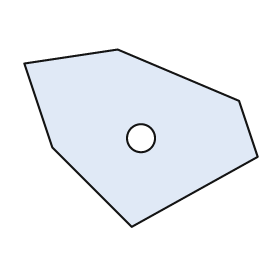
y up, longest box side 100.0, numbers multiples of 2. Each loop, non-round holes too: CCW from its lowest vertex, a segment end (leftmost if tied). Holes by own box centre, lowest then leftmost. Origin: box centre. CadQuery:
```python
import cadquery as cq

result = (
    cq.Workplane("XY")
    .moveTo(-4.0, -38.0)
    .lineTo(50.0, -8.0)
    .lineTo(42.0, 16.0)
    .lineTo(-10.0, 38.0)
    .lineTo(-50.0, 32.0)
    .lineTo(-38.0, -4.0)
    .close()
    .moveTo(0.0, 0.0)
    .circle(6.0)
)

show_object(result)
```